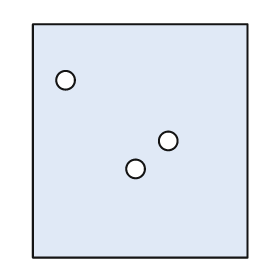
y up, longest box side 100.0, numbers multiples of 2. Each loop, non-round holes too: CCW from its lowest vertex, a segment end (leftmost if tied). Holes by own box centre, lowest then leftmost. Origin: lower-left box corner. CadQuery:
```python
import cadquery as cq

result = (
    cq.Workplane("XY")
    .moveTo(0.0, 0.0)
    .lineTo(92.0, 0.0)
    .lineTo(92.0, 100.0)
    .lineTo(0.0, 100.0)
    .close()
    .moveTo(44.0, 38.0)
    .circle(4.0)
    .moveTo(58.0, 50.0)
    .circle(4.0)
    .moveTo(14.0, 76.0)
    .circle(4.0)
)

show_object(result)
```